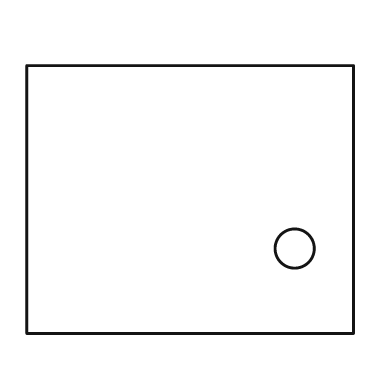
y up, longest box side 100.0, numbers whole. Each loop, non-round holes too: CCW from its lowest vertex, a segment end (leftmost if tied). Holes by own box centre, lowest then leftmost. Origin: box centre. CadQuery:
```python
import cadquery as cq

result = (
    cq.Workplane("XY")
    .moveTo(-50.0, -41.0)
    .lineTo(50.0, -41.0)
    .lineTo(50.0, 41.0)
    .lineTo(-50.0, 41.0)
    .close()
    .moveTo(32.0, -15.0)
    .circle(6.0)
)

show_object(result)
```